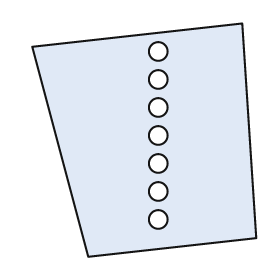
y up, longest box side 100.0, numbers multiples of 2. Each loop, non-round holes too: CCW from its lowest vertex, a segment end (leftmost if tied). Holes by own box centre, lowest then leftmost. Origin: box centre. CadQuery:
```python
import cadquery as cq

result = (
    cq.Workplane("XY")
    .moveTo(-24.0, -50.0)
    .lineTo(48.0, -42.0)
    .lineTo(42.0, 50.0)
    .lineTo(-48.0, 40.0)
    .close()
    .moveTo(6.0, -34.0)
    .circle(4.0)
    .moveTo(6.0, -22.0)
    .circle(4.0)
    .moveTo(6.0, -10.0)
    .circle(4.0)
    .moveTo(6.0, 2.0)
    .circle(4.0)
    .moveTo(6.0, 14.0)
    .circle(4.0)
    .moveTo(6.0, 26.0)
    .circle(4.0)
    .moveTo(6.0, 38.0)
    .circle(4.0)
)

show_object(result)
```